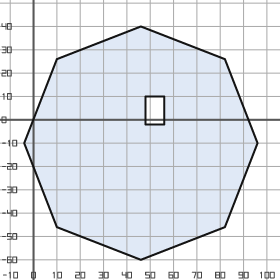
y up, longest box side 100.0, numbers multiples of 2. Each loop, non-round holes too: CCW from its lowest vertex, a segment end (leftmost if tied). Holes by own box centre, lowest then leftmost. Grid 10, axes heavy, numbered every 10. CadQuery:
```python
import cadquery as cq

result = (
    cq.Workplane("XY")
    .moveTo(46.0, -60.0)
    .lineTo(82.0, -46.0)
    .lineTo(96.0, -10.0)
    .lineTo(82.0, 26.0)
    .lineTo(46.0, 40.0)
    .lineTo(10.0, 26.0)
    .lineTo(-4.0, -10.0)
    .lineTo(10.0, -46.0)
    .close()
    .moveTo(48.0, -2.0)
    .lineTo(56.0, -2.0)
    .lineTo(56.0, 10.0)
    .lineTo(48.0, 10.0)
    .close()
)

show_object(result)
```